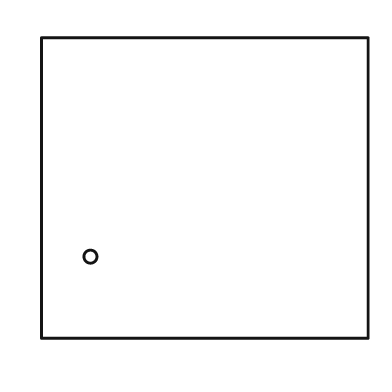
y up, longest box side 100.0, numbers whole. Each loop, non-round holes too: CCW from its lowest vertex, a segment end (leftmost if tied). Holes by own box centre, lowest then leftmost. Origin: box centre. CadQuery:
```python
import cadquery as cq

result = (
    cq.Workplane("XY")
    .moveTo(-50.0, -46.0)
    .lineTo(50.0, -46.0)
    .lineTo(50.0, 46.0)
    .lineTo(-50.0, 46.0)
    .close()
    .moveTo(-35.0, -21.0)
    .circle(2.0)
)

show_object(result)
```